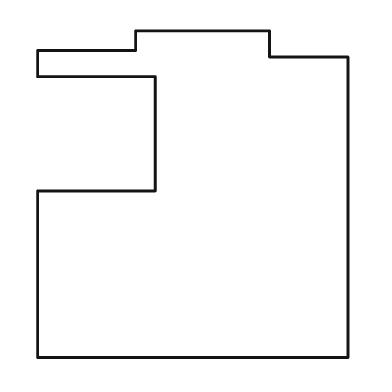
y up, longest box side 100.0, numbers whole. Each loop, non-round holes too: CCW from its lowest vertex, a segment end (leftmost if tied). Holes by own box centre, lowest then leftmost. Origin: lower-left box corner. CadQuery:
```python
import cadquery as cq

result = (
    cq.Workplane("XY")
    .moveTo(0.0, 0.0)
    .lineTo(95.0, 0.0)
    .lineTo(95.0, 92.0)
    .lineTo(71.0, 92.0)
    .lineTo(71.0, 100.0)
    .lineTo(30.0, 100.0)
    .lineTo(30.0, 94.0)
    .lineTo(0.0, 94.0)
    .lineTo(0.0, 86.0)
    .lineTo(36.0, 86.0)
    .lineTo(36.0, 51.0)
    .lineTo(0.0, 51.0)
    .close()
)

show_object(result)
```